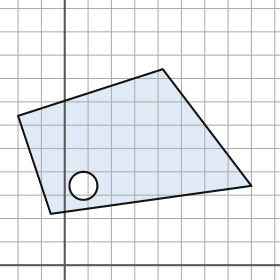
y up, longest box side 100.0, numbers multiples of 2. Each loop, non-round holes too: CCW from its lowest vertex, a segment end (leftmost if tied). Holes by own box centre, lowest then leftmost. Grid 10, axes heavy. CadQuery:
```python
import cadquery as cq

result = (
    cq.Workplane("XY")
    .moveTo(-6.0, 22.0)
    .lineTo(80.0, 34.0)
    .lineTo(42.0, 84.0)
    .lineTo(-20.0, 64.0)
    .close()
    .moveTo(8.0, 34.0)
    .circle(6.0)
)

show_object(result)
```